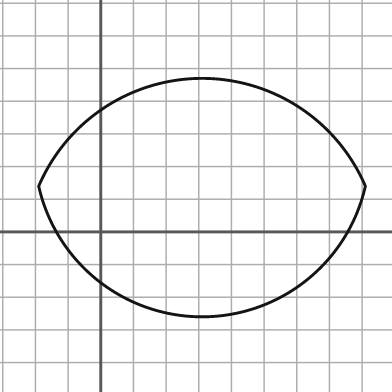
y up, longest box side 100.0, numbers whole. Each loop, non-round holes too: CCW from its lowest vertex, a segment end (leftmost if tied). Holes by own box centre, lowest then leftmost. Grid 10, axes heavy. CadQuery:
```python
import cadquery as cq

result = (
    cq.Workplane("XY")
    .moveTo(-19.0, 14.0)
    .threePointArc((31.0, -26.0), (81.0, 14.0))
    .threePointArc((31.0, 47.0), (-19.0, 14.0))
    .close()
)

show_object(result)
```